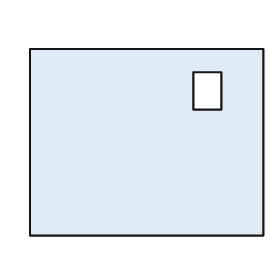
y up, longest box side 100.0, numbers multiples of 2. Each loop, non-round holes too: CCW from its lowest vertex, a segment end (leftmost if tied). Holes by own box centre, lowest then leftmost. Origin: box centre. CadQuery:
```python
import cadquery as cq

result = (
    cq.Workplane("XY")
    .moveTo(-50.0, -40.0)
    .lineTo(50.0, -40.0)
    .lineTo(50.0, 40.0)
    .lineTo(-50.0, 40.0)
    .close()
    .moveTo(20.0, 14.0)
    .lineTo(32.0, 14.0)
    .lineTo(32.0, 30.0)
    .lineTo(20.0, 30.0)
    .close()
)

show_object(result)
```